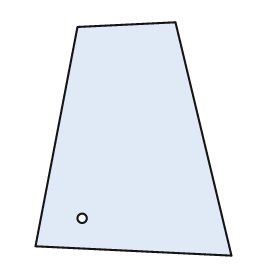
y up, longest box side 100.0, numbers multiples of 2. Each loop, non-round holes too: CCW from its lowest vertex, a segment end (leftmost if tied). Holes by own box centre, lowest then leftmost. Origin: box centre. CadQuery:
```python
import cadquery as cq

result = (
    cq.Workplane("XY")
    .moveTo(42.0, -50.0)
    .lineTo(18.0, 50.0)
    .lineTo(-24.0, 48.0)
    .lineTo(-42.0, -46.0)
    .close()
    .moveTo(-22.0, -34.0)
    .circle(2.0)
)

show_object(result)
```